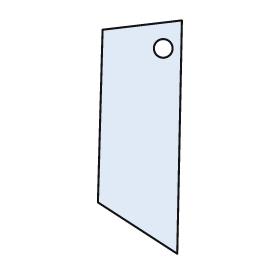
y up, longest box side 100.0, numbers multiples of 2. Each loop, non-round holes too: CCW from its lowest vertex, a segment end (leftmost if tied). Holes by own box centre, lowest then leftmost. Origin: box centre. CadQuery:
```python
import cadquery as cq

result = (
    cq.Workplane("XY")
    .moveTo(16.0, -50.0)
    .lineTo(18.0, 50.0)
    .lineTo(-16.0, 46.0)
    .lineTo(-18.0, -28.0)
    .close()
    .moveTo(10.0, 38.0)
    .circle(4.0)
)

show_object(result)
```